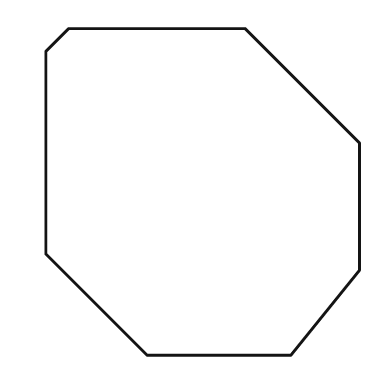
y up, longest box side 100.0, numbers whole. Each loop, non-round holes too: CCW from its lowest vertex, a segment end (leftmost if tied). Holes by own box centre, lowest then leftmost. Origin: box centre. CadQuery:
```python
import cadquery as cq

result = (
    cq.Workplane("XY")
    .moveTo(-17.0, -50.0)
    .lineTo(27.0, -50.0)
    .lineTo(48.0, -24.0)
    .lineTo(48.0, 15.0)
    .lineTo(13.0, 50.0)
    .lineTo(-41.0, 50.0)
    .lineTo(-48.0, 43.0)
    .lineTo(-48.0, -19.0)
    .close()
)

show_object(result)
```